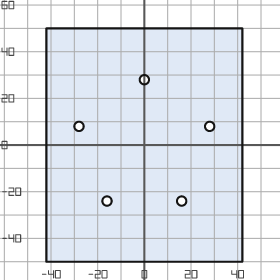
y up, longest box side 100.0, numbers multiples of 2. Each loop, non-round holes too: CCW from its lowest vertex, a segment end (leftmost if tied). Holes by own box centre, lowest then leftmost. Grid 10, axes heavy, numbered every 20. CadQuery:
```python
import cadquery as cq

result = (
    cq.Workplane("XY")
    .moveTo(-42.0, -50.0)
    .lineTo(42.0, -50.0)
    .lineTo(42.0, 50.0)
    .lineTo(-42.0, 50.0)
    .close()
    .moveTo(-16.0, -24.0)
    .circle(2.0)
    .moveTo(16.0, -24.0)
    .circle(2.0)
    .moveTo(-28.0, 8.0)
    .circle(2.0)
    .moveTo(28.0, 8.0)
    .circle(2.0)
    .moveTo(0.0, 28.0)
    .circle(2.0)
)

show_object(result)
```